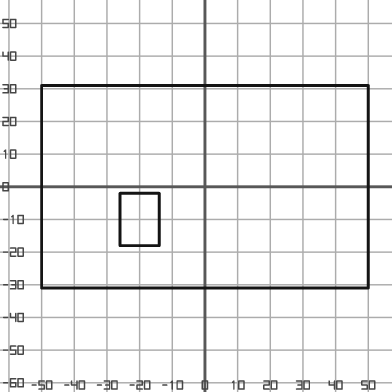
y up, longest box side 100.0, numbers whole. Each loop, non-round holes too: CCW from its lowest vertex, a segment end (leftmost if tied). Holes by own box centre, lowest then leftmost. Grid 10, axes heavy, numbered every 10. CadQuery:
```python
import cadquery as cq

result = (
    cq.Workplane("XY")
    .moveTo(-50.0, -31.0)
    .lineTo(50.0, -31.0)
    .lineTo(50.0, 31.0)
    .lineTo(-50.0, 31.0)
    .close()
    .moveTo(-26.0, -18.0)
    .lineTo(-14.0, -18.0)
    .lineTo(-14.0, -2.0)
    .lineTo(-26.0, -2.0)
    .close()
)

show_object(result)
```